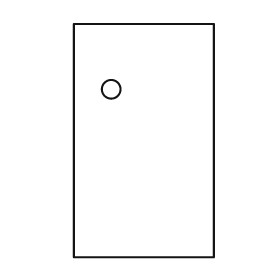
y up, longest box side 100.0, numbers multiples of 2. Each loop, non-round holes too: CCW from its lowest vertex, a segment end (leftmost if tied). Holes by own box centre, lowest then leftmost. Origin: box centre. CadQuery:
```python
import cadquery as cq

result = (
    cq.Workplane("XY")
    .moveTo(-30.0, -50.0)
    .lineTo(30.0, -50.0)
    .lineTo(30.0, 50.0)
    .lineTo(-30.0, 50.0)
    .close()
    .moveTo(-14.0, 22.0)
    .circle(4.0)
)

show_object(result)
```